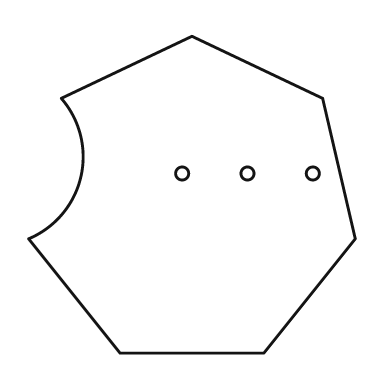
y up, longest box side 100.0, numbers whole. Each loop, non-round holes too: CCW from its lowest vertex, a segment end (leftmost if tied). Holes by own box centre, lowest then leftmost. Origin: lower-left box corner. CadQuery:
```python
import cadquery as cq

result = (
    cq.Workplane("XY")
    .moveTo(28.0, 0.0)
    .lineTo(72.0, 0.0)
    .lineTo(100.0, 35.0)
    .lineTo(90.0, 78.0)
    .lineTo(50.0, 97.0)
    .lineTo(10.0, 78.0)
    .threePointArc((16.0, 54.0), (0.0, 35.0))
    .close()
    .moveTo(47.0, 55.0)
    .circle(2.0)
    .moveTo(67.0, 55.0)
    .circle(2.0)
    .moveTo(87.0, 55.0)
    .circle(2.0)
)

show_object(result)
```